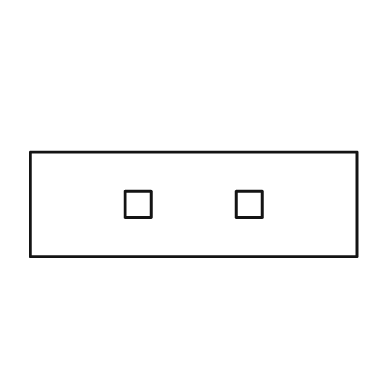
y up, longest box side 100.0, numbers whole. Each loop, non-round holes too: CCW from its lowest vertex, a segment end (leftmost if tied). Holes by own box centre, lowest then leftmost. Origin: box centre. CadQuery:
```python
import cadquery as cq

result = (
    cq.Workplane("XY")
    .moveTo(-50.0, -16.0)
    .lineTo(50.0, -16.0)
    .lineTo(50.0, 16.0)
    .lineTo(-50.0, 16.0)
    .close()
    .moveTo(-21.0, -4.0)
    .lineTo(-13.0, -4.0)
    .lineTo(-13.0, 4.0)
    .lineTo(-21.0, 4.0)
    .close()
    .moveTo(13.0, -4.0)
    .lineTo(21.0, -4.0)
    .lineTo(21.0, 4.0)
    .lineTo(13.0, 4.0)
    .close()
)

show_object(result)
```